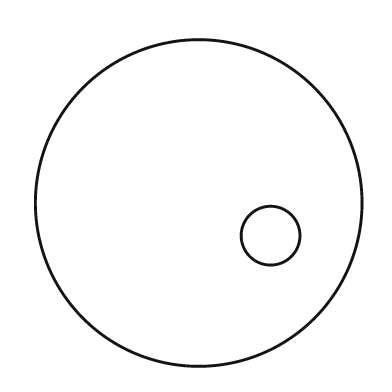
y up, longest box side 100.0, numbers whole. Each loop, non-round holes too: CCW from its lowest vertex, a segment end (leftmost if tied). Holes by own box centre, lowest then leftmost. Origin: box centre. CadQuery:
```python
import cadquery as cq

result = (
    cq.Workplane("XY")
    .moveTo(0.0, 0.0)
    .circle(50.0)
    .moveTo(22.0, -10.0)
    .circle(9.0)
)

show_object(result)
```